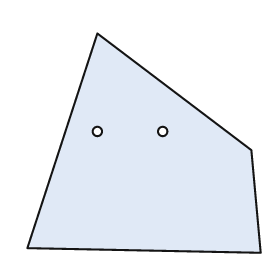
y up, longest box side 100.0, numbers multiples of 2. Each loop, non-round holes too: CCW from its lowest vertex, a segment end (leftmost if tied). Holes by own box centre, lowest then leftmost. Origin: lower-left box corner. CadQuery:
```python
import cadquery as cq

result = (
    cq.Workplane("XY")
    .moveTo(100.0, 0.0)
    .lineTo(96.0, 44.0)
    .lineTo(30.0, 94.0)
    .lineTo(0.0, 2.0)
    .close()
    .moveTo(30.0, 52.0)
    .circle(2.0)
    .moveTo(58.0, 52.0)
    .circle(2.0)
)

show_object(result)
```